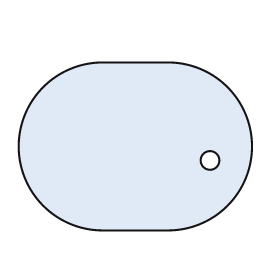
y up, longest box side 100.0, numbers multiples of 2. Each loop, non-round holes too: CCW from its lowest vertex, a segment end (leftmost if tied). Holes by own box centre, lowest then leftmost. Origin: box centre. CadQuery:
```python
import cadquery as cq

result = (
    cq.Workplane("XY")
    .moveTo(-14.0, -36.0)
    .lineTo(14.0, -36.0)
    .threePointArc((50.0, 0.0), (14.0, 36.0))
    .lineTo(-14.0, 36.0)
    .threePointArc((-50.0, 0.0), (-14.0, -36.0))
    .close()
    .moveTo(32.0, -6.0)
    .circle(4.0)
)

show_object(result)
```